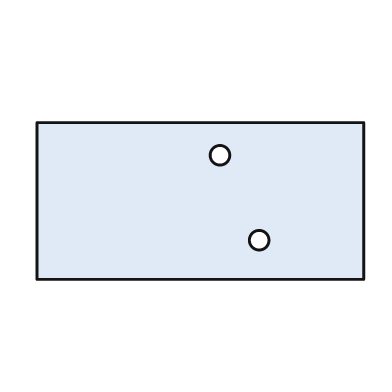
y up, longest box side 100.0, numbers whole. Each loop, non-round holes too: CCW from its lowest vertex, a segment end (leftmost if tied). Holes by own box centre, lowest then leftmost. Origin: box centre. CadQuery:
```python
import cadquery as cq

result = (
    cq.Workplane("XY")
    .moveTo(-50.0, -24.0)
    .lineTo(50.0, -24.0)
    .lineTo(50.0, 24.0)
    .lineTo(-50.0, 24.0)
    .close()
    .moveTo(18.0, -12.0)
    .circle(3.0)
    .moveTo(6.0, 14.0)
    .circle(3.0)
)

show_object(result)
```